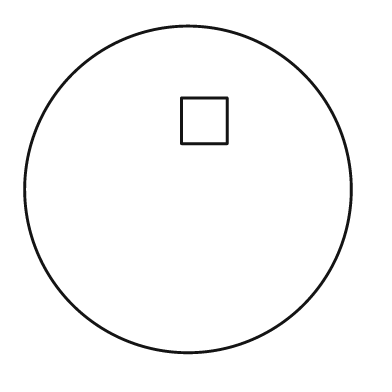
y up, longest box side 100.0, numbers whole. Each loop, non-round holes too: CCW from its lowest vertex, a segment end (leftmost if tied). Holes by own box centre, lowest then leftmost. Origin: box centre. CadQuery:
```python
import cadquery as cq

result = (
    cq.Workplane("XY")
    .moveTo(0.0, 0.0)
    .circle(50.0)
    .moveTo(-2.0, 14.0)
    .lineTo(12.0, 14.0)
    .lineTo(12.0, 28.0)
    .lineTo(-2.0, 28.0)
    .close()
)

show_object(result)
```